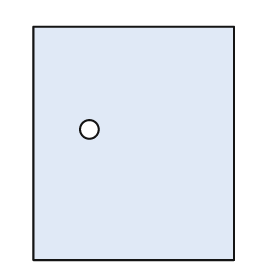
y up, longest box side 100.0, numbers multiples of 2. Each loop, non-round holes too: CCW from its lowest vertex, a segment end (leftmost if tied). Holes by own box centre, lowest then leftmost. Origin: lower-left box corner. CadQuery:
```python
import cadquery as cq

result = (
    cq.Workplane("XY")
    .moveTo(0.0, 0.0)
    .lineTo(86.0, 0.0)
    .lineTo(86.0, 100.0)
    .lineTo(0.0, 100.0)
    .close()
    .moveTo(24.0, 56.0)
    .circle(4.0)
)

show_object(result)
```